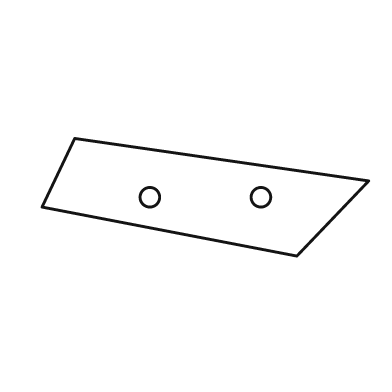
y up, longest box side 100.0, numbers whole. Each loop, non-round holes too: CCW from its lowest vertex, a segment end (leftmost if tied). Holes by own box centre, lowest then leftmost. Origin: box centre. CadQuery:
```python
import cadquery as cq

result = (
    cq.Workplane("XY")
    .moveTo(28.0, -18.0)
    .lineTo(50.0, 5.0)
    .lineTo(-40.0, 18.0)
    .lineTo(-50.0, -3.0)
    .close()
    .moveTo(-17.0, 0.0)
    .circle(3.0)
    .moveTo(17.0, 0.0)
    .circle(3.0)
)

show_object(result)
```